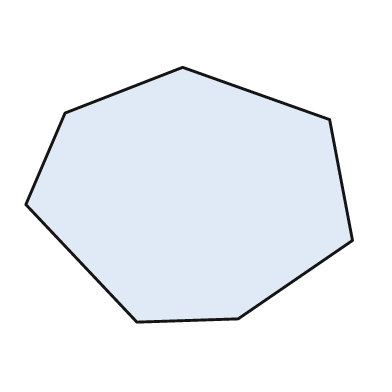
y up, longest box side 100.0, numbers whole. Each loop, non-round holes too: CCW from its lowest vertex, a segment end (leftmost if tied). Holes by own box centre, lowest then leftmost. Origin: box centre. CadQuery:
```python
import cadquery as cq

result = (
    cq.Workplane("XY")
    .moveTo(-16.0, -39.0)
    .lineTo(15.0, -38.0)
    .lineTo(50.0, -14.0)
    .lineTo(43.0, 23.0)
    .lineTo(-2.0, 39.0)
    .lineTo(-38.0, 25.0)
    .lineTo(-50.0, -3.0)
    .close()
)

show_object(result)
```